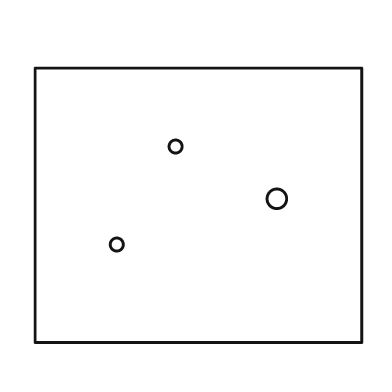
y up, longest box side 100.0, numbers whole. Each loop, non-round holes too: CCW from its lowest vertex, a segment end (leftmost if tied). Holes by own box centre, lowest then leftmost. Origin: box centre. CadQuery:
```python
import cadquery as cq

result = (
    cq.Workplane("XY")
    .moveTo(-50.0, -42.0)
    .lineTo(50.0, -42.0)
    .lineTo(50.0, 42.0)
    .lineTo(-50.0, 42.0)
    .close()
    .moveTo(-25.0, -12.0)
    .circle(2.0)
    .moveTo(24.0, 2.0)
    .circle(3.0)
    .moveTo(-7.0, 18.0)
    .circle(2.0)
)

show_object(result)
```